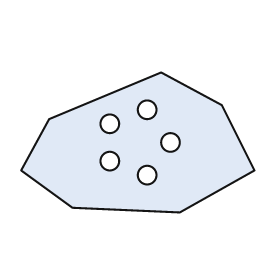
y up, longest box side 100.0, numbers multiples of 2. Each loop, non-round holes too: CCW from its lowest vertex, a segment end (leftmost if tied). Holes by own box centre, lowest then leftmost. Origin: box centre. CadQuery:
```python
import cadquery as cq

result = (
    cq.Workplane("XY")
    .moveTo(18.0, -30.0)
    .lineTo(50.0, -12.0)
    .lineTo(36.0, 16.0)
    .lineTo(10.0, 30.0)
    .lineTo(-38.0, 10.0)
    .lineTo(-50.0, -12.0)
    .lineTo(-28.0, -28.0)
    .close()
    .moveTo(4.0, -14.0)
    .circle(4.0)
    .moveTo(-12.0, -8.0)
    .circle(4.0)
    .moveTo(14.0, 0.0)
    .circle(4.0)
    .moveTo(-12.0, 8.0)
    .circle(4.0)
    .moveTo(4.0, 14.0)
    .circle(4.0)
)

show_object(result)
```